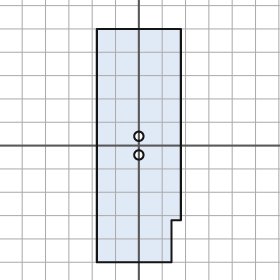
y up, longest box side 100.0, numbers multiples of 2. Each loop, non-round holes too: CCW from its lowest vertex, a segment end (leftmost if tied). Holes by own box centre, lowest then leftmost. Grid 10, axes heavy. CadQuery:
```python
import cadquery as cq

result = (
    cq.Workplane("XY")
    .moveTo(-18.0, -50.0)
    .lineTo(14.0, -50.0)
    .lineTo(14.0, -32.0)
    .lineTo(18.0, -32.0)
    .lineTo(18.0, 50.0)
    .lineTo(-18.0, 50.0)
    .close()
    .moveTo(0.0, -4.0)
    .circle(2.0)
    .moveTo(0.0, 4.0)
    .circle(2.0)
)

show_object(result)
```